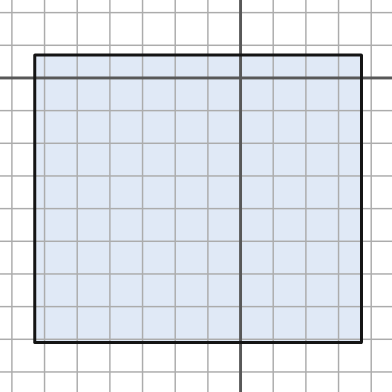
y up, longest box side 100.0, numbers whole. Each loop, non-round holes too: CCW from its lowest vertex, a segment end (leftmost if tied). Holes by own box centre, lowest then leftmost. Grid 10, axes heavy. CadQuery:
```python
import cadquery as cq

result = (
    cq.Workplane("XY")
    .moveTo(-63.0, -81.0)
    .lineTo(37.0, -81.0)
    .lineTo(37.0, 7.0)
    .lineTo(-63.0, 7.0)
    .close()
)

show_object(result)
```